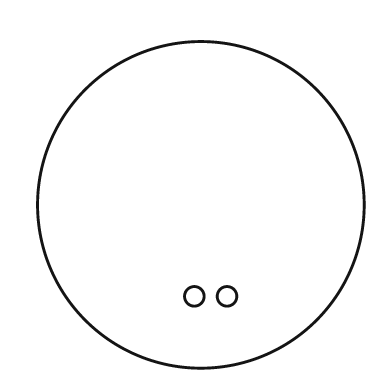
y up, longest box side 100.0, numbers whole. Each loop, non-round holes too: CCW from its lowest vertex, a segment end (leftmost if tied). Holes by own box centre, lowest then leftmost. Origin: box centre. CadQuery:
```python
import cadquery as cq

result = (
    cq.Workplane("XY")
    .moveTo(0.0, 0.0)
    .circle(50.0)
    .moveTo(-2.0, -28.0)
    .circle(3.0)
    .moveTo(8.0, -28.0)
    .circle(3.0)
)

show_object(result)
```